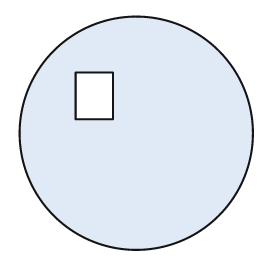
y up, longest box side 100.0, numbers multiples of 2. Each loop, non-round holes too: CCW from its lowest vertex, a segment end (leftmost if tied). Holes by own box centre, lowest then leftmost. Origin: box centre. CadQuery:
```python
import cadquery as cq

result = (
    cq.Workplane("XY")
    .moveTo(0.0, 0.0)
    .circle(50.0)
    .moveTo(-26.0, 6.0)
    .lineTo(-10.0, 6.0)
    .lineTo(-10.0, 26.0)
    .lineTo(-26.0, 26.0)
    .close()
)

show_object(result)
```